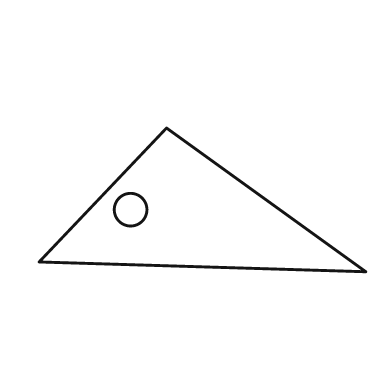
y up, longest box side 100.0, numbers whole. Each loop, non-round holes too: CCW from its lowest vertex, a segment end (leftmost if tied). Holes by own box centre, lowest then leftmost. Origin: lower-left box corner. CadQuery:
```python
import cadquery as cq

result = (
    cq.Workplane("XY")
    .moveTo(100.0, 0.0)
    .lineTo(39.0, 44.0)
    .lineTo(0.0, 3.0)
    .close()
    .moveTo(28.0, 19.0)
    .circle(5.0)
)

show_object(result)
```